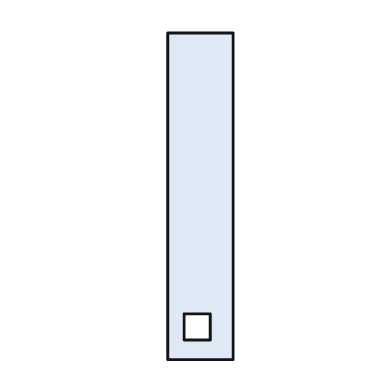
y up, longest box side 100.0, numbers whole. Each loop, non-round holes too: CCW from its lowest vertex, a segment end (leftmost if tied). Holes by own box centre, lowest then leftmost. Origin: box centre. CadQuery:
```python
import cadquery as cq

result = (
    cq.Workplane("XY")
    .moveTo(-10.0, -50.0)
    .lineTo(10.0, -50.0)
    .lineTo(10.0, 50.0)
    .lineTo(-10.0, 50.0)
    .close()
    .moveTo(-5.0, -44.0)
    .lineTo(3.0, -44.0)
    .lineTo(3.0, -36.0)
    .lineTo(-5.0, -36.0)
    .close()
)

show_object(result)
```